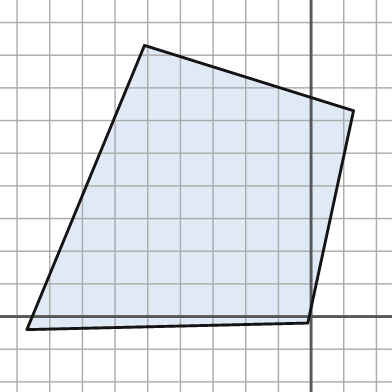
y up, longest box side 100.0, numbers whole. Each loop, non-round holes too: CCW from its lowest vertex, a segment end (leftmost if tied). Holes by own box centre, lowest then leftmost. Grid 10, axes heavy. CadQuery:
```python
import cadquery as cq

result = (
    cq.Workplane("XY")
    .moveTo(-87.0, -4.0)
    .lineTo(-1.0, -2.0)
    .lineTo(13.0, 63.0)
    .lineTo(-51.0, 83.0)
    .close()
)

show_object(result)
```